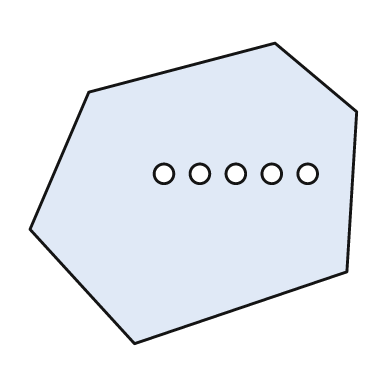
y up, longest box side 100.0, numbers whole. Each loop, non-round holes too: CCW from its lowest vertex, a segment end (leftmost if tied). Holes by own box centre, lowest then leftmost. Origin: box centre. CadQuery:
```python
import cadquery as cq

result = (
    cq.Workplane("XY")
    .moveTo(-18.0, -46.0)
    .lineTo(47.0, -24.0)
    .lineTo(50.0, 25.0)
    .lineTo(25.0, 46.0)
    .lineTo(-32.0, 31.0)
    .lineTo(-50.0, -11.0)
    .close()
    .moveTo(-9.0, 6.0)
    .circle(3.0)
    .moveTo(2.0, 6.0)
    .circle(3.0)
    .moveTo(13.0, 6.0)
    .circle(3.0)
    .moveTo(24.0, 6.0)
    .circle(3.0)
    .moveTo(35.0, 6.0)
    .circle(3.0)
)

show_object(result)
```